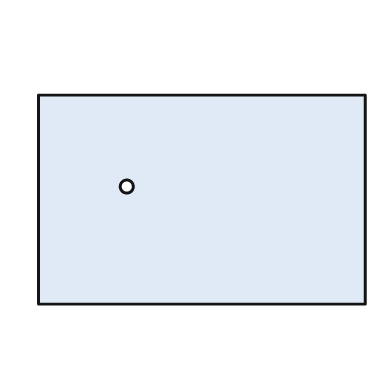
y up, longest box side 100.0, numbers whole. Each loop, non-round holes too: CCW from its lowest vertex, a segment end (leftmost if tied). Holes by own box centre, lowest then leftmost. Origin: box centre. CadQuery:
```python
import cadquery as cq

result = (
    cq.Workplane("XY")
    .moveTo(-50.0, -32.0)
    .lineTo(50.0, -32.0)
    .lineTo(50.0, 32.0)
    .lineTo(-50.0, 32.0)
    .close()
    .moveTo(-23.0, 4.0)
    .circle(2.0)
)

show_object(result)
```